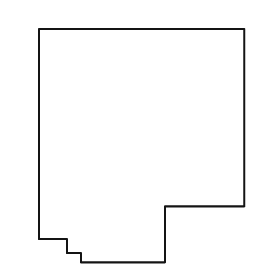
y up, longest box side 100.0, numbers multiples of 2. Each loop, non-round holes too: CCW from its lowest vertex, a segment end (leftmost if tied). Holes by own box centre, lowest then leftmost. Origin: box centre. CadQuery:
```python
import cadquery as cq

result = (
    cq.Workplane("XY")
    .moveTo(-26.0, -50.0)
    .lineTo(10.0, -50.0)
    .lineTo(10.0, -26.0)
    .lineTo(44.0, -26.0)
    .lineTo(44.0, 50.0)
    .lineTo(-44.0, 50.0)
    .lineTo(-44.0, -40.0)
    .lineTo(-32.0, -40.0)
    .lineTo(-32.0, -46.0)
    .lineTo(-26.0, -46.0)
    .close()
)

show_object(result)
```